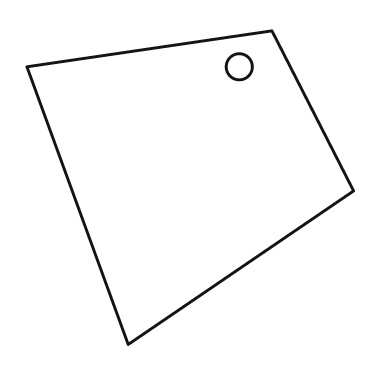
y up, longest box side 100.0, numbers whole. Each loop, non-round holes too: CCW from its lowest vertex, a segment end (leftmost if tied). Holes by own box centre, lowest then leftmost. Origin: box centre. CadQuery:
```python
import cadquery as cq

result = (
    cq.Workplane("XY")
    .moveTo(-19.0, -48.0)
    .lineTo(50.0, -1.0)
    .lineTo(25.0, 48.0)
    .lineTo(-50.0, 37.0)
    .close()
    .moveTo(15.0, 37.0)
    .circle(4.0)
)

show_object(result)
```